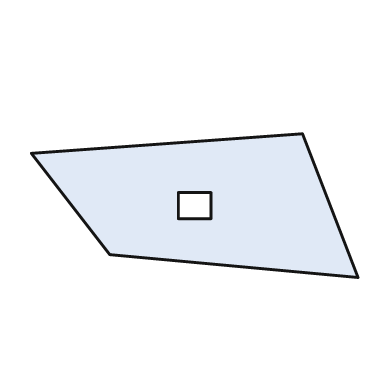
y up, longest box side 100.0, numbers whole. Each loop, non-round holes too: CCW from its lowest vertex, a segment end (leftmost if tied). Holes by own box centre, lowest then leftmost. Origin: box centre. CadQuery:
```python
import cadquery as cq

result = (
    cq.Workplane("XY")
    .moveTo(50.0, -22.0)
    .lineTo(33.0, 22.0)
    .lineTo(-50.0, 16.0)
    .lineTo(-26.0, -15.0)
    .close()
    .moveTo(-5.0, -4.0)
    .lineTo(5.0, -4.0)
    .lineTo(5.0, 4.0)
    .lineTo(-5.0, 4.0)
    .close()
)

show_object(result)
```